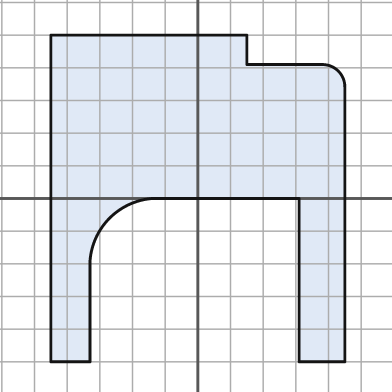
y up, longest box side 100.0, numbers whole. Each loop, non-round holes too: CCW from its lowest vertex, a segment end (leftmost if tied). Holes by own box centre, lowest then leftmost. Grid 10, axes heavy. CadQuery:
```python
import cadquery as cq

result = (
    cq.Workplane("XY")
    .moveTo(-45.0, -50.0)
    .lineTo(-33.0, -50.0)
    .lineTo(-33.0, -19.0)
    .threePointArc((-27.0, -6.0), (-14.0, 0.0))
    .lineTo(31.0, 0.0)
    .lineTo(31.0, -50.0)
    .lineTo(45.0, -50.0)
    .lineTo(45.0, 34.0)
    .threePointArc((43.0, 39.0), (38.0, 41.0))
    .lineTo(15.0, 41.0)
    .lineTo(15.0, 50.0)
    .lineTo(-45.0, 50.0)
    .close()
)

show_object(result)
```